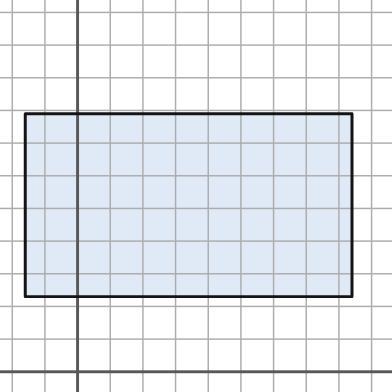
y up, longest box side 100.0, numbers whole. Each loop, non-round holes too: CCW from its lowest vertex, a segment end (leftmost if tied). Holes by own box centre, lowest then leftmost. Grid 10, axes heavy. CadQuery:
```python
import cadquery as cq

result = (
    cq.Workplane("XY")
    .moveTo(-16.0, 23.0)
    .lineTo(84.0, 23.0)
    .lineTo(84.0, 79.0)
    .lineTo(-16.0, 79.0)
    .close()
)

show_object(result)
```